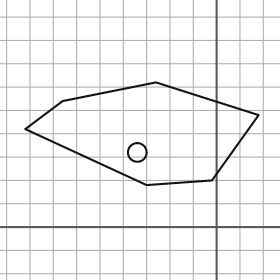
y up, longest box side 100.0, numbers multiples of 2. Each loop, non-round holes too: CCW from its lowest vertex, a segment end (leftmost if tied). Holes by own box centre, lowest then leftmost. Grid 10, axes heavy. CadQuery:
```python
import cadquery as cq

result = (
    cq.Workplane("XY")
    .moveTo(-30.0, 18.0)
    .lineTo(-2.0, 20.0)
    .lineTo(18.0, 48.0)
    .lineTo(-26.0, 62.0)
    .lineTo(-66.0, 54.0)
    .lineTo(-82.0, 42.0)
    .close()
    .moveTo(-34.0, 32.0)
    .circle(4.0)
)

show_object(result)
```